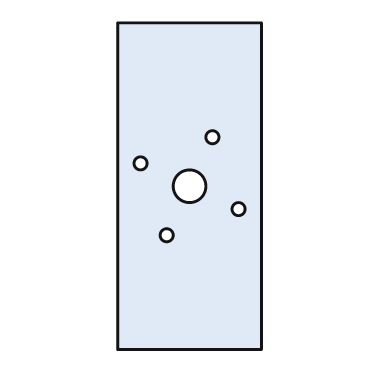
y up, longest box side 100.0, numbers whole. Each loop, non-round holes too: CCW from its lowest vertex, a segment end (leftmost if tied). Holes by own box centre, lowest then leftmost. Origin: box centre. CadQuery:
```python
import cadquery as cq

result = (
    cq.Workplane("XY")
    .moveTo(-22.0, -50.0)
    .lineTo(22.0, -50.0)
    .lineTo(22.0, 50.0)
    .lineTo(-22.0, 50.0)
    .close()
    .moveTo(-7.0, -15.0)
    .circle(2.0)
    .moveTo(15.0, -7.0)
    .circle(2.0)
    .moveTo(0.0, 0.0)
    .circle(5.0)
    .moveTo(-15.0, 7.0)
    .circle(2.0)
    .moveTo(7.0, 15.0)
    .circle(2.0)
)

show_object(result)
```